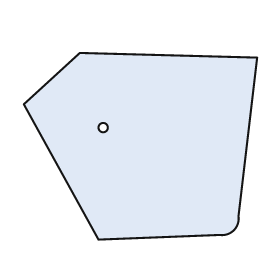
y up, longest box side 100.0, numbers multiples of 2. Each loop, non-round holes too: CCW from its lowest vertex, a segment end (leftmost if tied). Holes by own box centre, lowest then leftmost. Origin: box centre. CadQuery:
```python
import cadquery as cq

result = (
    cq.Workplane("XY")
    .moveTo(-18.0, -40.0)
    .lineTo(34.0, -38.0)
    .threePointArc((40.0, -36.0), (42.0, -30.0))
    .lineTo(50.0, 38.0)
    .lineTo(-26.0, 40.0)
    .lineTo(-50.0, 18.0)
    .close()
    .moveTo(-16.0, 8.0)
    .circle(2.0)
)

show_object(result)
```